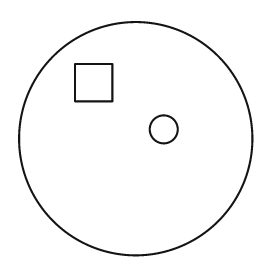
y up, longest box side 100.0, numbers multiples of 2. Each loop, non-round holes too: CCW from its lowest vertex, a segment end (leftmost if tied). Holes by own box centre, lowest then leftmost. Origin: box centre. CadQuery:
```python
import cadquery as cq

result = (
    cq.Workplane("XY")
    .moveTo(0.0, 0.0)
    .circle(50.0)
    .moveTo(12.0, 4.0)
    .circle(6.0)
    .moveTo(-26.0, 16.0)
    .lineTo(-10.0, 16.0)
    .lineTo(-10.0, 32.0)
    .lineTo(-26.0, 32.0)
    .close()
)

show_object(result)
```